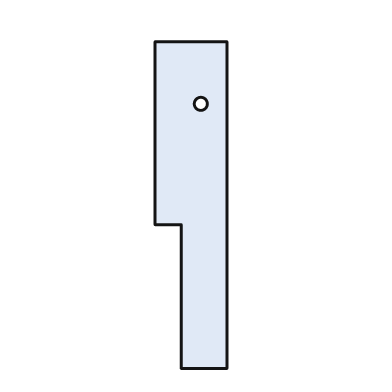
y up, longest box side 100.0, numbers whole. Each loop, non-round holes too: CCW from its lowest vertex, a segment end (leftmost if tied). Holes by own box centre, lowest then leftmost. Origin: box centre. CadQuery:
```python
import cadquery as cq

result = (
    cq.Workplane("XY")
    .moveTo(-3.0, -50.0)
    .lineTo(11.0, -50.0)
    .lineTo(11.0, 50.0)
    .lineTo(-11.0, 50.0)
    .lineTo(-11.0, -6.0)
    .lineTo(-3.0, -6.0)
    .close()
    .moveTo(3.0, 31.0)
    .circle(2.0)
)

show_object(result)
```